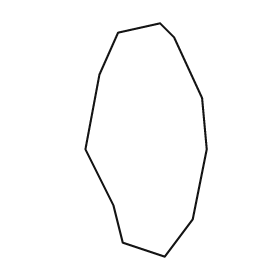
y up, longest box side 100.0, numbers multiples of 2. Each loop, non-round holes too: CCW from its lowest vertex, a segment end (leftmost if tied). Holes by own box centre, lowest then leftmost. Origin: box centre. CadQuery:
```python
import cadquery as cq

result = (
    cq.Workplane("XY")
    .moveTo(8.0, -50.0)
    .lineTo(20.0, -34.0)
    .lineTo(26.0, -4.0)
    .lineTo(24.0, 18.0)
    .lineTo(12.0, 44.0)
    .lineTo(6.0, 50.0)
    .lineTo(-12.0, 46.0)
    .lineTo(-20.0, 28.0)
    .lineTo(-26.0, -4.0)
    .lineTo(-14.0, -28.0)
    .lineTo(-10.0, -44.0)
    .close()
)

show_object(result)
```